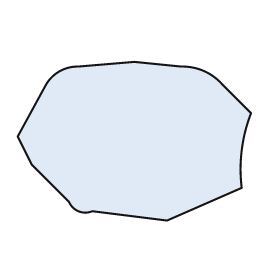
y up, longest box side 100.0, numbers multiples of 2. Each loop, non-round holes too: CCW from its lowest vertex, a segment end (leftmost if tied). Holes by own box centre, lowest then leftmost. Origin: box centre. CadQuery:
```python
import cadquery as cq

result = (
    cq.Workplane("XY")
    .moveTo(14.0, -34.0)
    .lineTo(46.0, -20.0)
    .threePointArc((46.0, -4.0), (50.0, 12.0))
    .lineTo(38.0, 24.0)
    .threePointArc((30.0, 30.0), (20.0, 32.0))
    .lineTo(0.0, 34.0)
    .lineTo(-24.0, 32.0)
    .threePointArc((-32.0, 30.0), (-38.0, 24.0))
    .lineTo(-50.0, 2.0)
    .lineTo(-44.0, -10.0)
    .lineTo(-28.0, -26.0)
    .threePointArc((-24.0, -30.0), (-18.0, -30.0))
    .close()
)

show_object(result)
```